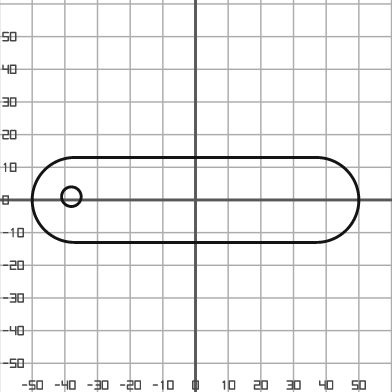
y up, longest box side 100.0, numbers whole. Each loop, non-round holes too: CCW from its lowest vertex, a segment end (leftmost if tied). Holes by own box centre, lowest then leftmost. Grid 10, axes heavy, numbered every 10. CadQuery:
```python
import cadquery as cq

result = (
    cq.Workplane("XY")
    .moveTo(-37.0, -13.0)
    .lineTo(37.0, -13.0)
    .threePointArc((50.0, 0.0), (37.0, 13.0))
    .lineTo(-37.0, 13.0)
    .threePointArc((-50.0, 0.0), (-37.0, -13.0))
    .close()
    .moveTo(-38.0, 1.0)
    .circle(3.0)
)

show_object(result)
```